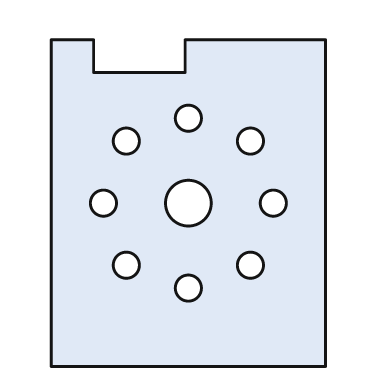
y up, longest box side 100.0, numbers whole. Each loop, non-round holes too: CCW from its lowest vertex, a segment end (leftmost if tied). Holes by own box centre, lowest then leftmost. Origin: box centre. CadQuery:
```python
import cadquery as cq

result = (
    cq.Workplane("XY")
    .moveTo(-42.0, -50.0)
    .lineTo(42.0, -50.0)
    .lineTo(42.0, 50.0)
    .lineTo(-1.0, 50.0)
    .lineTo(-1.0, 40.0)
    .lineTo(-29.0, 40.0)
    .lineTo(-29.0, 50.0)
    .lineTo(-42.0, 50.0)
    .close()
    .moveTo(0.0, -26.0)
    .circle(4.0)
    .moveTo(-19.0, -19.0)
    .circle(4.0)
    .moveTo(19.0, -19.0)
    .circle(4.0)
    .moveTo(-26.0, 0.0)
    .circle(4.0)
    .moveTo(0.0, 0.0)
    .circle(7.0)
    .moveTo(26.0, 0.0)
    .circle(4.0)
    .moveTo(-19.0, 19.0)
    .circle(4.0)
    .moveTo(19.0, 19.0)
    .circle(4.0)
    .moveTo(0.0, 26.0)
    .circle(4.0)
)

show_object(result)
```